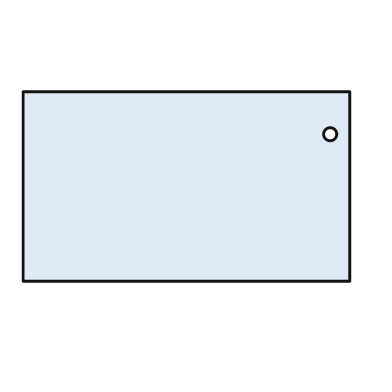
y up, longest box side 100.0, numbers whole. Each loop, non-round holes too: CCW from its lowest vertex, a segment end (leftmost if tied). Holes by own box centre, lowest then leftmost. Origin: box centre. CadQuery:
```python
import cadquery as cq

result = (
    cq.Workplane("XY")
    .moveTo(-50.0, -29.0)
    .lineTo(50.0, -29.0)
    .lineTo(50.0, 29.0)
    .lineTo(-50.0, 29.0)
    .close()
    .moveTo(44.0, 16.0)
    .circle(2.0)
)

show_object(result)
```